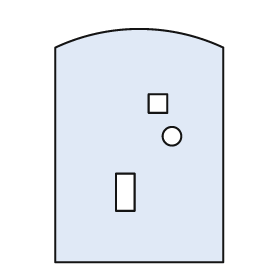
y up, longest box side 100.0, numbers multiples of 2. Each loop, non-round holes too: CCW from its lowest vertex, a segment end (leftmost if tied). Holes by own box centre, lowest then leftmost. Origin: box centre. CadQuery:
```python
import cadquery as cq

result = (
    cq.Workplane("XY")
    .moveTo(-36.0, -50.0)
    .lineTo(36.0, -50.0)
    .lineTo(36.0, 42.0)
    .threePointArc((0.0, 50.0), (-36.0, 42.0))
    .close()
    .moveTo(-10.0, -28.0)
    .lineTo(-2.0, -28.0)
    .lineTo(-2.0, -12.0)
    .lineTo(-10.0, -12.0)
    .close()
    .moveTo(14.0, 4.0)
    .circle(4.0)
    .moveTo(4.0, 14.0)
    .lineTo(12.0, 14.0)
    .lineTo(12.0, 22.0)
    .lineTo(4.0, 22.0)
    .close()
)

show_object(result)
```